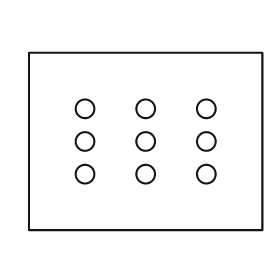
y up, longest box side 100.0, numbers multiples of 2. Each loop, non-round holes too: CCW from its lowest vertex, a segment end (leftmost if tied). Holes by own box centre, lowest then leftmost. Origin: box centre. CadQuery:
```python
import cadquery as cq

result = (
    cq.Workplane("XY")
    .moveTo(-50.0, -38.0)
    .lineTo(50.0, -38.0)
    .lineTo(50.0, 38.0)
    .lineTo(-50.0, 38.0)
    .close()
    .moveTo(-26.0, -14.0)
    .circle(4.0)
    .moveTo(0.0, -14.0)
    .circle(4.0)
    .moveTo(26.0, -14.0)
    .circle(4.0)
    .moveTo(-26.0, 0.0)
    .circle(4.0)
    .moveTo(0.0, 0.0)
    .circle(4.0)
    .moveTo(26.0, 0.0)
    .circle(4.0)
    .moveTo(-26.0, 14.0)
    .circle(4.0)
    .moveTo(0.0, 14.0)
    .circle(4.0)
    .moveTo(26.0, 14.0)
    .circle(4.0)
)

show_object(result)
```